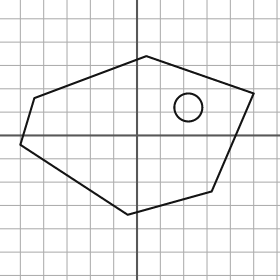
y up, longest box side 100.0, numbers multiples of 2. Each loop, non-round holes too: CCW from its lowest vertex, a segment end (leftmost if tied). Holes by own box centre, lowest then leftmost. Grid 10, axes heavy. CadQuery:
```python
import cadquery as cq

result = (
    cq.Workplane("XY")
    .moveTo(-4.0, -34.0)
    .lineTo(32.0, -24.0)
    .lineTo(50.0, 18.0)
    .lineTo(4.0, 34.0)
    .lineTo(-44.0, 16.0)
    .lineTo(-50.0, -4.0)
    .close()
    .moveTo(22.0, 12.0)
    .circle(6.0)
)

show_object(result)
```